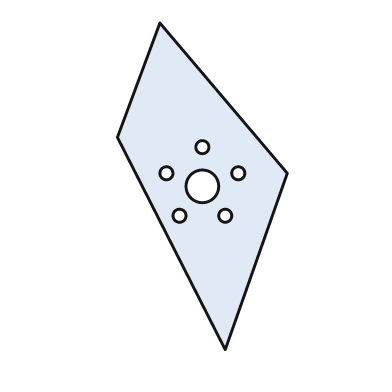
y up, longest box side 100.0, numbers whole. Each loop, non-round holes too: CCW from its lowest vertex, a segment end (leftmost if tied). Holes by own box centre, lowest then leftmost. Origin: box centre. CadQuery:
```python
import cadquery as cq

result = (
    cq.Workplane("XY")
    .moveTo(7.0, -50.0)
    .lineTo(26.0, 4.0)
    .lineTo(-13.0, 50.0)
    .lineTo(-26.0, 15.0)
    .close()
    .moveTo(-7.0, -9.0)
    .circle(2.0)
    .moveTo(7.0, -9.0)
    .circle(2.0)
    .moveTo(0.0, 0.0)
    .circle(5.0)
    .moveTo(-11.0, 4.0)
    .circle(2.0)
    .moveTo(11.0, 4.0)
    .circle(2.0)
    .moveTo(0.0, 12.0)
    .circle(2.0)
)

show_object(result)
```